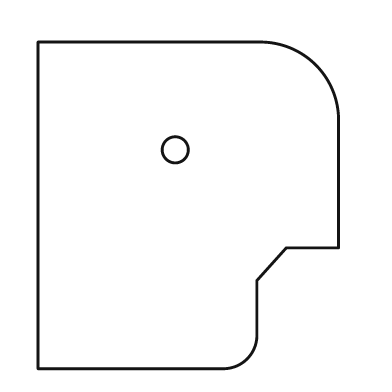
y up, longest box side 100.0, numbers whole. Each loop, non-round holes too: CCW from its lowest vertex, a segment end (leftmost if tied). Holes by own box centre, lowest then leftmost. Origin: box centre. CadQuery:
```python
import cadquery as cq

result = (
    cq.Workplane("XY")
    .moveTo(-46.0, -50.0)
    .lineTo(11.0, -50.0)
    .threePointArc((18.0, -47.0), (21.0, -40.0))
    .lineTo(21.0, -23.0)
    .lineTo(30.0, -13.0)
    .lineTo(46.0, -13.0)
    .lineTo(46.0, 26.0)
    .threePointArc((39.0, 43.0), (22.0, 50.0))
    .lineTo(-46.0, 50.0)
    .close()
    .moveTo(-4.0, 17.0)
    .circle(4.0)
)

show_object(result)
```